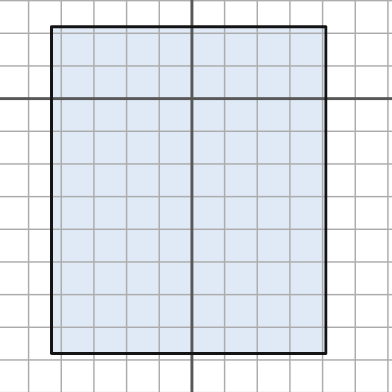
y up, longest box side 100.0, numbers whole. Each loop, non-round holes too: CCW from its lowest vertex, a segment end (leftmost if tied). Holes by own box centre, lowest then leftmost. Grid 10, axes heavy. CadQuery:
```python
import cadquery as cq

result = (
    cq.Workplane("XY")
    .moveTo(-43.0, -78.0)
    .lineTo(41.0, -78.0)
    .lineTo(41.0, 22.0)
    .lineTo(-43.0, 22.0)
    .close()
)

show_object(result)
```